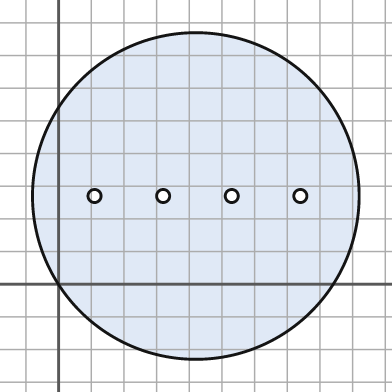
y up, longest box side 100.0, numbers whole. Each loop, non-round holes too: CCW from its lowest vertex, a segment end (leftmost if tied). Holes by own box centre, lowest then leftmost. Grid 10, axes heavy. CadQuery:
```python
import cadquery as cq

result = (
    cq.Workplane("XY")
    .moveTo(42.0, 27.0)
    .circle(50.0)
    .moveTo(11.0, 27.0)
    .circle(2.0)
    .moveTo(32.0, 27.0)
    .circle(2.0)
    .moveTo(53.0, 27.0)
    .circle(2.0)
    .moveTo(74.0, 27.0)
    .circle(2.0)
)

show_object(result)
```